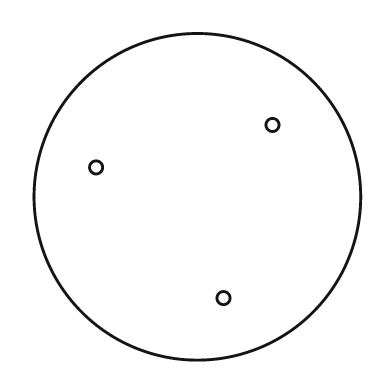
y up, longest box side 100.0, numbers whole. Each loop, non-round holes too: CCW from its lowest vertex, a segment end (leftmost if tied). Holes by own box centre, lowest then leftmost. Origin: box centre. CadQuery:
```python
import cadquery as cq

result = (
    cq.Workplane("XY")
    .moveTo(0.0, 0.0)
    .circle(50.0)
    .moveTo(8.0, -31.0)
    .circle(2.0)
    .moveTo(-31.0, 9.0)
    .circle(2.0)
    .moveTo(23.0, 22.0)
    .circle(2.0)
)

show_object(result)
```